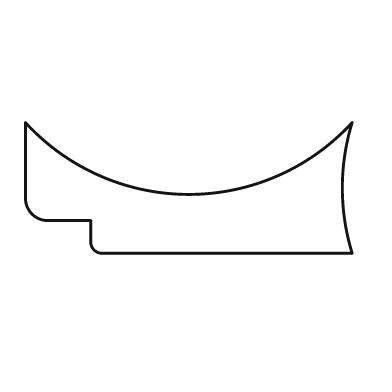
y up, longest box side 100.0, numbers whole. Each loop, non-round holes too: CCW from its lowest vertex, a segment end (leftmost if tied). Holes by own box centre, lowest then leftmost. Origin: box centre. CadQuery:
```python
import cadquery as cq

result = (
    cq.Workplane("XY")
    .moveTo(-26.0, -20.0)
    .lineTo(50.0, -20.0)
    .threePointArc((47.0, 0.0), (50.0, 20.0))
    .threePointArc((0.0, -2.0), (-50.0, 20.0))
    .lineTo(-50.0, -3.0)
    .threePointArc((-48.0, -8.0), (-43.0, -10.0))
    .lineTo(-30.0, -10.0)
    .lineTo(-30.0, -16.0)
    .threePointArc((-29.0, -19.0), (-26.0, -20.0))
    .close()
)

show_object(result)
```